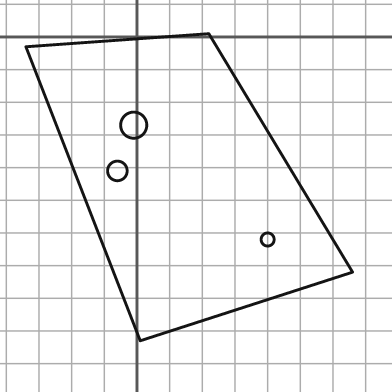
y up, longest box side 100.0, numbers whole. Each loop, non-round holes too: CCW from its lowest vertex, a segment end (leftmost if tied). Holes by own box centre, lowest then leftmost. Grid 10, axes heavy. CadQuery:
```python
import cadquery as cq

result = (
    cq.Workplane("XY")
    .moveTo(1.0, -93.0)
    .lineTo(66.0, -72.0)
    .lineTo(22.0, 1.0)
    .lineTo(-34.0, -3.0)
    .close()
    .moveTo(40.0, -62.0)
    .circle(2.0)
    .moveTo(-6.0, -41.0)
    .circle(3.0)
    .moveTo(-1.0, -27.0)
    .circle(4.0)
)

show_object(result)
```